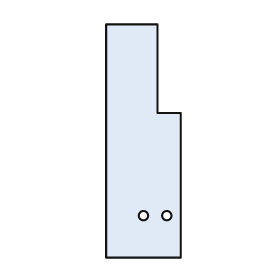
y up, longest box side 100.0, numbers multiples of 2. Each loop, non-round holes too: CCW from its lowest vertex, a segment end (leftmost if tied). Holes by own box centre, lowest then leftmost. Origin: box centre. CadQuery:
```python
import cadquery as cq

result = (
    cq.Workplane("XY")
    .moveTo(-16.0, -50.0)
    .lineTo(16.0, -50.0)
    .lineTo(16.0, 12.0)
    .lineTo(6.0, 12.0)
    .lineTo(6.0, 50.0)
    .lineTo(-16.0, 50.0)
    .close()
    .moveTo(0.0, -32.0)
    .circle(2.0)
    .moveTo(10.0, -32.0)
    .circle(2.0)
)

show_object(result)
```